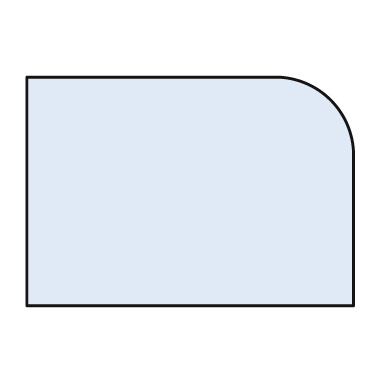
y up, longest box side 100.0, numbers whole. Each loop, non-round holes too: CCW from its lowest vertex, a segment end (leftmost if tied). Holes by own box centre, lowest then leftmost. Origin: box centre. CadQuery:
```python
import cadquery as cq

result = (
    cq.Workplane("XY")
    .moveTo(-50.0, -35.0)
    .lineTo(50.0, -35.0)
    .lineTo(50.0, 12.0)
    .threePointArc((43.0, 28.0), (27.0, 35.0))
    .lineTo(-50.0, 35.0)
    .close()
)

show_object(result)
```